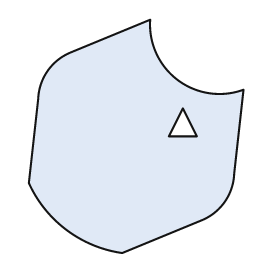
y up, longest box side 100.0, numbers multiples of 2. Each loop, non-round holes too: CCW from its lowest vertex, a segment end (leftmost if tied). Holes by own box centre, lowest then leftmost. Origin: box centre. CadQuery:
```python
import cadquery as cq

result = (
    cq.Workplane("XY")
    .moveTo(-6.0, -50.0)
    .lineTo(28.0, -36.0)
    .threePointArc((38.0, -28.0), (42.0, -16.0))
    .lineTo(46.0, 20.0)
    .threePointArc((18.0, 24.0), (6.0, 50.0))
    .lineTo(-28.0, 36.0)
    .threePointArc((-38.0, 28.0), (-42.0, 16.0))
    .lineTo(-46.0, -20.0)
    .threePointArc((-30.0, -40.0), (-6.0, -50.0))
    .close()
    .moveTo(14.0, 0.0)
    .lineTo(26.0, 0.0)
    .lineTo(20.0, 12.0)
    .close()
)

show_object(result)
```